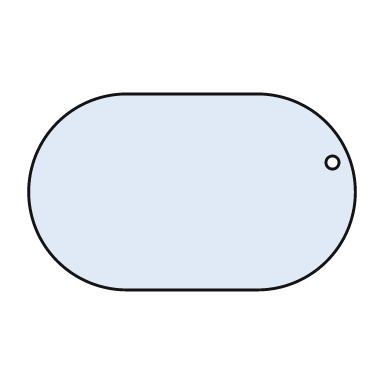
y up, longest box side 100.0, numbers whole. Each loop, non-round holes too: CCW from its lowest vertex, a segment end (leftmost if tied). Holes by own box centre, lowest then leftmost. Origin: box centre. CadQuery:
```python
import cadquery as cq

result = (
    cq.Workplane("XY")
    .moveTo(-20.0, -30.0)
    .lineTo(20.0, -30.0)
    .threePointArc((50.0, 0.0), (20.0, 30.0))
    .lineTo(-20.0, 30.0)
    .threePointArc((-50.0, 0.0), (-20.0, -30.0))
    .close()
    .moveTo(43.0, 9.0)
    .circle(2.0)
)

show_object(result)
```